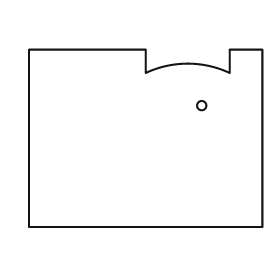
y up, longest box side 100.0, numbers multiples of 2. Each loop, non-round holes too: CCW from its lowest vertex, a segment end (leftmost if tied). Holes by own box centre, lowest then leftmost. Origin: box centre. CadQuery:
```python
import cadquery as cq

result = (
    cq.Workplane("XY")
    .moveTo(-50.0, -38.0)
    .lineTo(50.0, -38.0)
    .lineTo(50.0, 38.0)
    .lineTo(36.0, 38.0)
    .lineTo(36.0, 28.0)
    .threePointArc((18.0, 32.0), (0.0, 28.0))
    .lineTo(0.0, 38.0)
    .lineTo(-50.0, 38.0)
    .close()
    .moveTo(24.0, 14.0)
    .circle(2.0)
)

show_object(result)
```